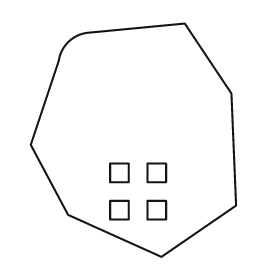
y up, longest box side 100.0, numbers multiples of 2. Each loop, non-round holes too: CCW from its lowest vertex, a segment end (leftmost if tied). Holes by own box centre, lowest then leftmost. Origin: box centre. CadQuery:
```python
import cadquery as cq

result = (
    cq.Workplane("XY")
    .moveTo(12.0, -50.0)
    .lineTo(44.0, -28.0)
    .lineTo(42.0, 20.0)
    .lineTo(22.0, 50.0)
    .lineTo(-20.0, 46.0)
    .threePointArc((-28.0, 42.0), (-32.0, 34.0))
    .lineTo(-44.0, -2.0)
    .lineTo(-28.0, -32.0)
    .close()
    .moveTo(-10.0, -34.0)
    .lineTo(-2.0, -34.0)
    .lineTo(-2.0, -26.0)
    .lineTo(-10.0, -26.0)
    .close()
    .moveTo(6.0, -34.0)
    .lineTo(14.0, -34.0)
    .lineTo(14.0, -26.0)
    .lineTo(6.0, -26.0)
    .close()
    .moveTo(-10.0, -18.0)
    .lineTo(-2.0, -18.0)
    .lineTo(-2.0, -10.0)
    .lineTo(-10.0, -10.0)
    .close()
    .moveTo(6.0, -18.0)
    .lineTo(14.0, -18.0)
    .lineTo(14.0, -10.0)
    .lineTo(6.0, -10.0)
    .close()
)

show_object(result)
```